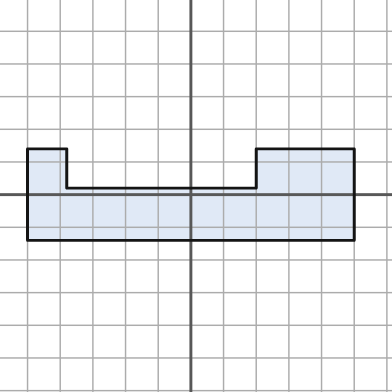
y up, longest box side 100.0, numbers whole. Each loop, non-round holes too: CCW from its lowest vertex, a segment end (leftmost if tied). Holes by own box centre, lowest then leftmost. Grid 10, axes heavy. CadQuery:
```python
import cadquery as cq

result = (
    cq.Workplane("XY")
    .moveTo(-50.0, -14.0)
    .lineTo(50.0, -14.0)
    .lineTo(50.0, 14.0)
    .lineTo(20.0, 14.0)
    .lineTo(20.0, 2.0)
    .lineTo(-38.0, 2.0)
    .lineTo(-38.0, 14.0)
    .lineTo(-50.0, 14.0)
    .close()
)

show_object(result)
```